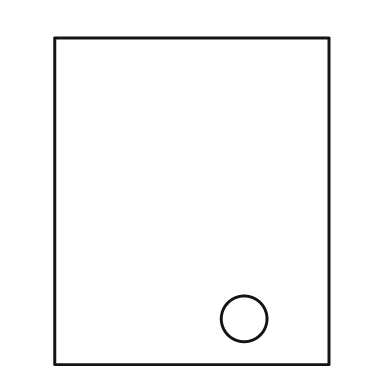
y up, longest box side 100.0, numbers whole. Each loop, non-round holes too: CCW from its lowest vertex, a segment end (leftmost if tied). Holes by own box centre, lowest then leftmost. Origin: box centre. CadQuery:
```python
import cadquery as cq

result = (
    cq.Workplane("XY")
    .moveTo(-42.0, -50.0)
    .lineTo(42.0, -50.0)
    .lineTo(42.0, 50.0)
    .lineTo(-42.0, 50.0)
    .close()
    .moveTo(16.0, -36.0)
    .circle(7.0)
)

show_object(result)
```